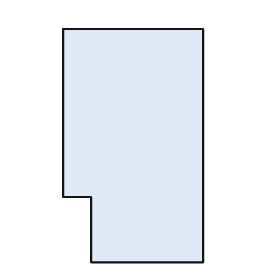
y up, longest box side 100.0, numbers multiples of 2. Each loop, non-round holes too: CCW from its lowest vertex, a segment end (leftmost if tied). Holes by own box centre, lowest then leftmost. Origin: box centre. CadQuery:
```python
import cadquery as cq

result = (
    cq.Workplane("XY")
    .moveTo(-18.0, -50.0)
    .lineTo(30.0, -50.0)
    .lineTo(30.0, 50.0)
    .lineTo(-30.0, 50.0)
    .lineTo(-30.0, -22.0)
    .lineTo(-18.0, -22.0)
    .close()
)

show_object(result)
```